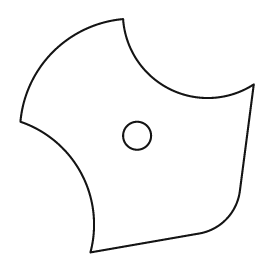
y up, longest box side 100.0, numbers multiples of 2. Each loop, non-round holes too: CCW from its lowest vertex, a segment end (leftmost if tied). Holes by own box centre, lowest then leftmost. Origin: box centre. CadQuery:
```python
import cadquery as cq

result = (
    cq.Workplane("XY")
    .moveTo(-20.0, -50.0)
    .lineTo(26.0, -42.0)
    .threePointArc((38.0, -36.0), (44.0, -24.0))
    .lineTo(50.0, 22.0)
    .threePointArc((14.0, 20.0), (-6.0, 50.0))
    .threePointArc((-36.0, 36.0), (-50.0, 6.0))
    .threePointArc((-24.0, -16.0), (-20.0, -50.0))
    .close()
    .moveTo(0.0, 0.0)
    .circle(6.0)
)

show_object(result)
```